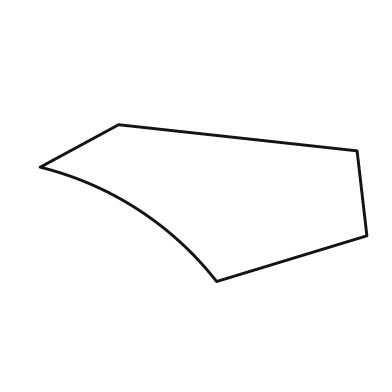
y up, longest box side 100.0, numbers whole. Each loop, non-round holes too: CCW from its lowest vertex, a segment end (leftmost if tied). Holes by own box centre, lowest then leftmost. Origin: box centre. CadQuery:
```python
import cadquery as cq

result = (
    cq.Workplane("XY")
    .moveTo(4.0, -24.0)
    .lineTo(50.0, -10.0)
    .lineTo(47.0, 16.0)
    .lineTo(-26.0, 24.0)
    .lineTo(-50.0, 11.0)
    .threePointArc((-20.0, -2.0), (4.0, -24.0))
    .close()
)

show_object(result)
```